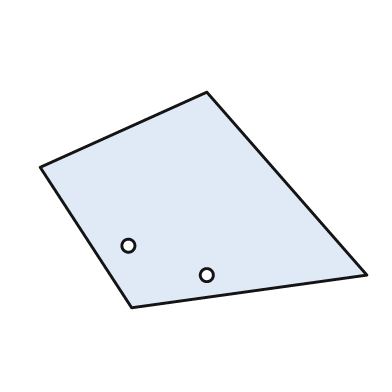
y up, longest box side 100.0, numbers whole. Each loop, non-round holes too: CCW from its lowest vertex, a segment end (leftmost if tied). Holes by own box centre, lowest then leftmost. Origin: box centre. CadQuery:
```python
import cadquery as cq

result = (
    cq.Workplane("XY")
    .moveTo(-22.0, -33.0)
    .lineTo(50.0, -23.0)
    .lineTo(1.0, 33.0)
    .lineTo(-50.0, 10.0)
    .close()
    .moveTo(1.0, -23.0)
    .circle(2.0)
    .moveTo(-23.0, -14.0)
    .circle(2.0)
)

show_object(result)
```